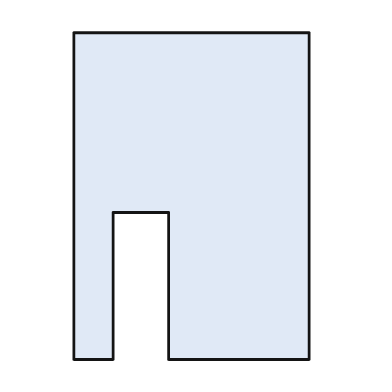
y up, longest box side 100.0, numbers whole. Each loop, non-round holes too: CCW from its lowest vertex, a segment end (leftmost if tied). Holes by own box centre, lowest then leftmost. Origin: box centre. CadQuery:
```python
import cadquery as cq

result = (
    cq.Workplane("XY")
    .moveTo(-36.0, -50.0)
    .lineTo(-24.0, -50.0)
    .lineTo(-24.0, -5.0)
    .lineTo(-7.0, -5.0)
    .lineTo(-7.0, -50.0)
    .lineTo(36.0, -50.0)
    .lineTo(36.0, 50.0)
    .lineTo(-36.0, 50.0)
    .close()
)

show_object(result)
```